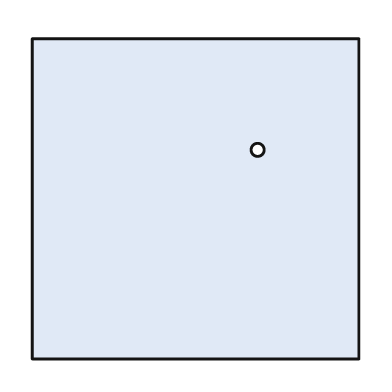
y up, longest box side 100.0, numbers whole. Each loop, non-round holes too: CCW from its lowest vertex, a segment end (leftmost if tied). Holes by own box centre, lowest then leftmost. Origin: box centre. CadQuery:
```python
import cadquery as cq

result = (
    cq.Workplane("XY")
    .moveTo(-50.0, -49.0)
    .lineTo(50.0, -49.0)
    .lineTo(50.0, 49.0)
    .lineTo(-50.0, 49.0)
    .close()
    .moveTo(19.0, 15.0)
    .circle(2.0)
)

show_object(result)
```